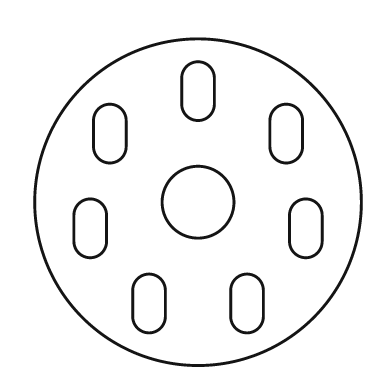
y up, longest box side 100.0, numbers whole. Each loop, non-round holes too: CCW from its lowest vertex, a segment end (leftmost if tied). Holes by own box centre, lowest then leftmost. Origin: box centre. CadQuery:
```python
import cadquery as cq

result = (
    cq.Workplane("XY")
    .moveTo(0.0, 0.0)
    .circle(50.0)
    .moveTo(-20.0, -35.0)
    .threePointArc((-15.0, -40.0), (-10.0, -35.0))
    .lineTo(-10.0, -27.0)
    .threePointArc((-15.0, -22.0), (-20.0, -27.0))
    .close()
    .moveTo(10.0, -35.0)
    .threePointArc((15.0, -40.0), (20.0, -35.0))
    .lineTo(20.0, -27.0)
    .threePointArc((15.0, -22.0), (10.0, -27.0))
    .close()
    .moveTo(-38.0, -12.0)
    .threePointArc((-33.0, -17.0), (-28.0, -12.0))
    .lineTo(-28.0, -4.0)
    .threePointArc((-33.0, 1.0), (-38.0, -4.0))
    .close()
    .moveTo(28.0, -12.0)
    .threePointArc((33.0, -17.0), (38.0, -12.0))
    .lineTo(38.0, -4.0)
    .threePointArc((33.0, 1.0), (28.0, -4.0))
    .close()
    .moveTo(0.0, 0.0)
    .circle(11.0)
    .moveTo(-32.0, 17.0)
    .threePointArc((-27.0, 12.0), (-22.0, 17.0))
    .lineTo(-22.0, 25.0)
    .threePointArc((-27.0, 30.0), (-32.0, 25.0))
    .close()
    .moveTo(22.0, 17.0)
    .threePointArc((27.0, 12.0), (32.0, 17.0))
    .lineTo(32.0, 25.0)
    .threePointArc((27.0, 30.0), (22.0, 25.0))
    .close()
    .moveTo(-5.0, 30.0)
    .threePointArc((0.0, 25.0), (5.0, 30.0))
    .lineTo(5.0, 38.0)
    .threePointArc((0.0, 43.0), (-5.0, 38.0))
    .close()
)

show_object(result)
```